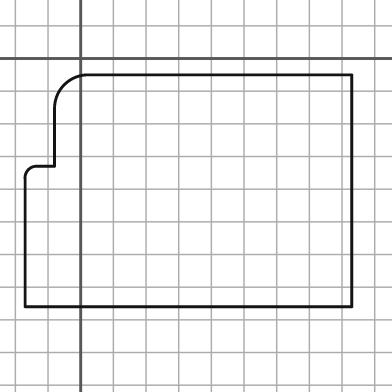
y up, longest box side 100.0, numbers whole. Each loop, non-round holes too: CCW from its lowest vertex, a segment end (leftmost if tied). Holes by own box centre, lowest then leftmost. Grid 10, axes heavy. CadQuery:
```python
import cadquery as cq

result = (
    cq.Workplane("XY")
    .moveTo(-17.0, -76.0)
    .lineTo(83.0, -76.0)
    .lineTo(83.0, -5.0)
    .lineTo(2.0, -5.0)
    .threePointArc((-5.0, -8.0), (-8.0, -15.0))
    .lineTo(-8.0, -33.0)
    .lineTo(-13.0, -33.0)
    .threePointArc((-16.0, -34.0), (-17.0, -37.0))
    .close()
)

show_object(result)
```